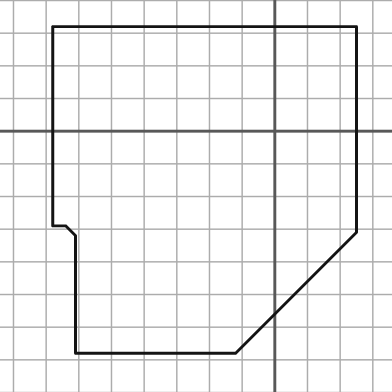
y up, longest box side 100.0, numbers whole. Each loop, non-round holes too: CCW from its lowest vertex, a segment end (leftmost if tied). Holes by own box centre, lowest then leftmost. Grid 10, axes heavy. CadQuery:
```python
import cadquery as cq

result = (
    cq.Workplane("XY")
    .moveTo(-61.0, -68.0)
    .lineTo(-12.0, -68.0)
    .lineTo(25.0, -31.0)
    .lineTo(25.0, 32.0)
    .lineTo(-68.0, 32.0)
    .lineTo(-68.0, -29.0)
    .lineTo(-64.0, -29.0)
    .lineTo(-61.0, -32.0)
    .close()
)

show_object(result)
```